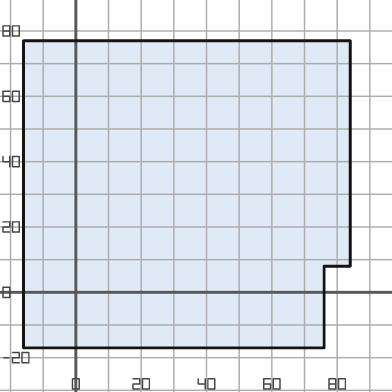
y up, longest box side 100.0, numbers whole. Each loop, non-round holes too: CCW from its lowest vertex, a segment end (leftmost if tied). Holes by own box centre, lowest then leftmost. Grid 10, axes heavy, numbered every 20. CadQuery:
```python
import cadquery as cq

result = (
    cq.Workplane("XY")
    .moveTo(-16.0, -17.0)
    .lineTo(76.0, -17.0)
    .lineTo(76.0, 8.0)
    .lineTo(84.0, 8.0)
    .lineTo(84.0, 77.0)
    .lineTo(-16.0, 77.0)
    .close()
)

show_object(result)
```